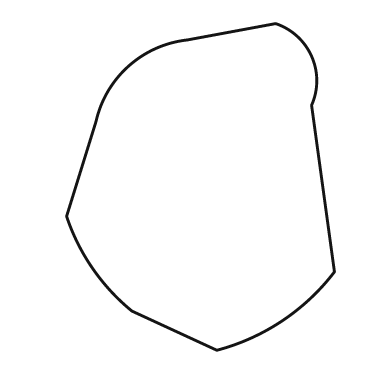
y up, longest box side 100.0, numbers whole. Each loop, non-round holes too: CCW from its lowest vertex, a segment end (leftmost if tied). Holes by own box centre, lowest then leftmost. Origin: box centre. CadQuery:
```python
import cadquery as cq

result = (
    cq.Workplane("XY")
    .moveTo(5.0, -50.0)
    .threePointArc((25.0, -41.0), (41.0, -26.0))
    .lineTo(34.0, 25.0)
    .threePointArc((34.0, 40.0), (23.0, 50.0))
    .lineTo(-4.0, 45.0)
    .threePointArc((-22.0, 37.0), (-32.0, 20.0))
    .lineTo(-41.0, -9.0)
    .threePointArc((-33.0, -25.0), (-21.0, -38.0))
    .close()
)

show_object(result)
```